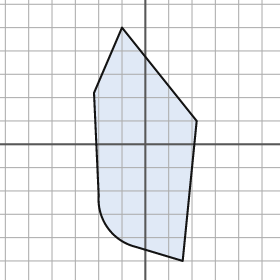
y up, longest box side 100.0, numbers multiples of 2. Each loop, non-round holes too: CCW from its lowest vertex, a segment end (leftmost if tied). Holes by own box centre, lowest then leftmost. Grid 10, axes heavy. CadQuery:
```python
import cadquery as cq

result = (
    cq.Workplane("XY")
    .moveTo(16.0, -50.0)
    .lineTo(22.0, 10.0)
    .lineTo(-10.0, 50.0)
    .lineTo(-22.0, 22.0)
    .lineTo(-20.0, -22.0)
    .threePointArc((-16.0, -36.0), (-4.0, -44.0))
    .close()
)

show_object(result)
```